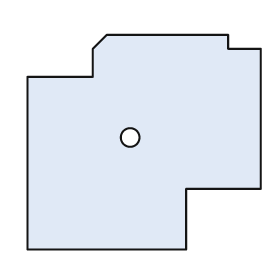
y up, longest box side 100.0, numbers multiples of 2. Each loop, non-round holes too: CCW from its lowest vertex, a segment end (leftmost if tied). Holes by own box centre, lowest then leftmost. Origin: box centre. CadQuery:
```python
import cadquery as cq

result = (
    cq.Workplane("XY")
    .moveTo(-50.0, -46.0)
    .lineTo(18.0, -46.0)
    .lineTo(18.0, -20.0)
    .lineTo(50.0, -20.0)
    .lineTo(50.0, 40.0)
    .lineTo(36.0, 40.0)
    .lineTo(36.0, 46.0)
    .lineTo(-16.0, 46.0)
    .lineTo(-22.0, 40.0)
    .lineTo(-22.0, 28.0)
    .lineTo(-50.0, 28.0)
    .close()
    .moveTo(-6.0, 2.0)
    .circle(4.0)
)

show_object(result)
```